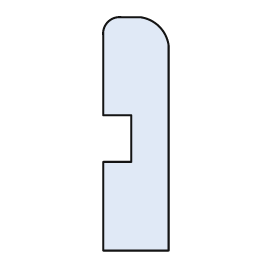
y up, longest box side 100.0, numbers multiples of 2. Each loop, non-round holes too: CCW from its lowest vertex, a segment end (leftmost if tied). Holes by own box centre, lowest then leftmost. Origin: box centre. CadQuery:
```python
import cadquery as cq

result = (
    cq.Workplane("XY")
    .moveTo(-14.0, -50.0)
    .lineTo(14.0, -50.0)
    .lineTo(14.0, 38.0)
    .threePointArc((10.0, 46.0), (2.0, 50.0))
    .lineTo(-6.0, 50.0)
    .threePointArc((-12.0, 48.0), (-14.0, 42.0))
    .lineTo(-14.0, 8.0)
    .lineTo(-2.0, 8.0)
    .lineTo(-2.0, -12.0)
    .lineTo(-14.0, -12.0)
    .close()
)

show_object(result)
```